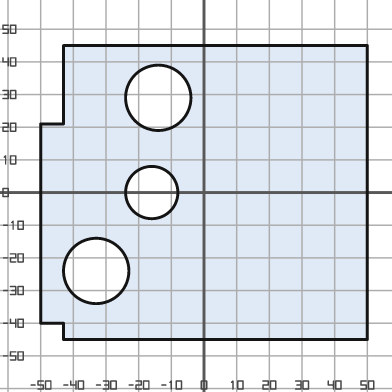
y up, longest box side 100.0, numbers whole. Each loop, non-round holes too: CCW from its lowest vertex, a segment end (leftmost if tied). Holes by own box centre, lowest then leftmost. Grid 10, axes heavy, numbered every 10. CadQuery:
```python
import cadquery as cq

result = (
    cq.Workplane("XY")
    .moveTo(-43.0, -45.0)
    .lineTo(50.0, -45.0)
    .lineTo(50.0, 45.0)
    .lineTo(-43.0, 45.0)
    .lineTo(-43.0, 21.0)
    .lineTo(-50.0, 21.0)
    .lineTo(-50.0, -40.0)
    .lineTo(-43.0, -40.0)
    .close()
    .moveTo(-33.0, -24.0)
    .circle(10.0)
    .moveTo(-16.0, 0.0)
    .circle(8.0)
    .moveTo(-14.0, 29.0)
    .circle(10.0)
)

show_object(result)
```